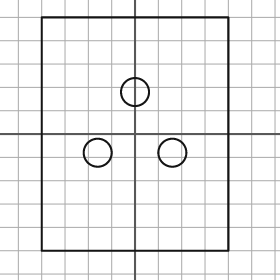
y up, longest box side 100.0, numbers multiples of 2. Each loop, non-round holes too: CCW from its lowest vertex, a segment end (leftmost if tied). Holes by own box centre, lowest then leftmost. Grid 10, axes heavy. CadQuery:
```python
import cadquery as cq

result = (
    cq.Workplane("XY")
    .moveTo(-40.0, -50.0)
    .lineTo(40.0, -50.0)
    .lineTo(40.0, 50.0)
    .lineTo(-40.0, 50.0)
    .close()
    .moveTo(-16.0, -8.0)
    .circle(6.0)
    .moveTo(16.0, -8.0)
    .circle(6.0)
    .moveTo(0.0, 18.0)
    .circle(6.0)
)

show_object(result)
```